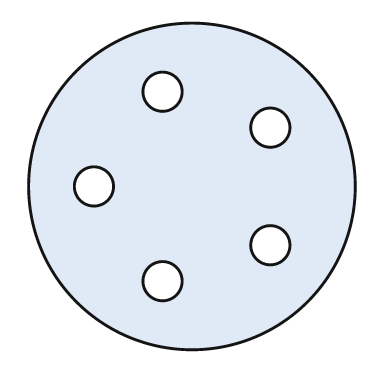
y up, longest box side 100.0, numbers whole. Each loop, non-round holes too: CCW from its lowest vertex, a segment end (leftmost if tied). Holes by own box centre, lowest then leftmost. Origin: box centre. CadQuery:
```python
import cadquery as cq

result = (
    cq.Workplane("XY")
    .moveTo(0.0, 0.0)
    .circle(50.0)
    .moveTo(-9.0, -29.0)
    .circle(6.0)
    .moveTo(24.0, -18.0)
    .circle(6.0)
    .moveTo(-30.0, 0.0)
    .circle(6.0)
    .moveTo(24.0, 18.0)
    .circle(6.0)
    .moveTo(-9.0, 29.0)
    .circle(6.0)
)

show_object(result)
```